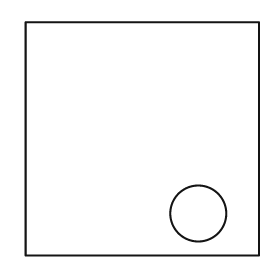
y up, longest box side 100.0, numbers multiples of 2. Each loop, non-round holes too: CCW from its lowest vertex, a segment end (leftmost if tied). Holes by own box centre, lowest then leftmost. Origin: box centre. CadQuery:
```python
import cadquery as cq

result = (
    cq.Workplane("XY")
    .moveTo(-50.0, -50.0)
    .lineTo(50.0, -50.0)
    .lineTo(50.0, 50.0)
    .lineTo(-50.0, 50.0)
    .close()
    .moveTo(24.0, -32.0)
    .circle(12.0)
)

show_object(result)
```